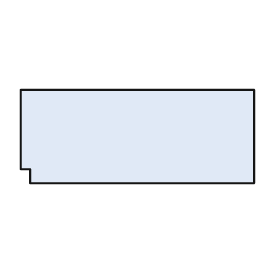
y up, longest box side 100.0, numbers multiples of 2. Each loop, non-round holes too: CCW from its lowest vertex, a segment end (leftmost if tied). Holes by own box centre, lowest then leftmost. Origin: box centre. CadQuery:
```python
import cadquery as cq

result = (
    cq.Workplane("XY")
    .moveTo(-46.0, -20.0)
    .lineTo(50.0, -20.0)
    .lineTo(50.0, 20.0)
    .lineTo(-50.0, 20.0)
    .lineTo(-50.0, -14.0)
    .lineTo(-46.0, -14.0)
    .close()
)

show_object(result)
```